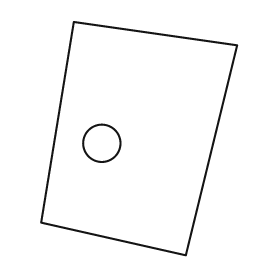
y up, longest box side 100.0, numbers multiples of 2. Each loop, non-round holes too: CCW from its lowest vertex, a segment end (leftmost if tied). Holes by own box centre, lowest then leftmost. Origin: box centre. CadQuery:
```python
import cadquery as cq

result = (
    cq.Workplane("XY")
    .moveTo(20.0, -50.0)
    .lineTo(42.0, 40.0)
    .lineTo(-28.0, 50.0)
    .lineTo(-42.0, -36.0)
    .close()
    .moveTo(-16.0, -2.0)
    .circle(8.0)
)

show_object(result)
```